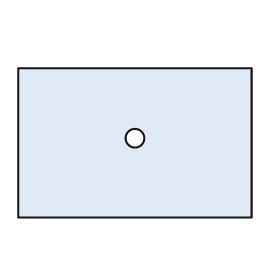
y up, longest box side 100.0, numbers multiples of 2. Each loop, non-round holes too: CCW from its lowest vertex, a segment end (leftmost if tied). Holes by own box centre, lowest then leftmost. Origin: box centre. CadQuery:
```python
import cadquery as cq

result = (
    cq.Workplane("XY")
    .moveTo(-50.0, -32.0)
    .lineTo(50.0, -32.0)
    .lineTo(50.0, 32.0)
    .lineTo(-50.0, 32.0)
    .close()
    .moveTo(0.0, 2.0)
    .circle(4.0)
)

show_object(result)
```